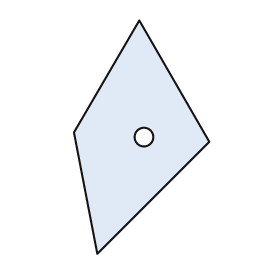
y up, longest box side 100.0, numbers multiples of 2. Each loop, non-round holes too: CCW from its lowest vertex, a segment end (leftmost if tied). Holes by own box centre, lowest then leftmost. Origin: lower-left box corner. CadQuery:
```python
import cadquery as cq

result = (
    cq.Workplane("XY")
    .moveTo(10.0, 0.0)
    .lineTo(58.0, 48.0)
    .lineTo(28.0, 100.0)
    .lineTo(0.0, 52.0)
    .close()
    .moveTo(30.0, 50.0)
    .circle(4.0)
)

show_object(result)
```